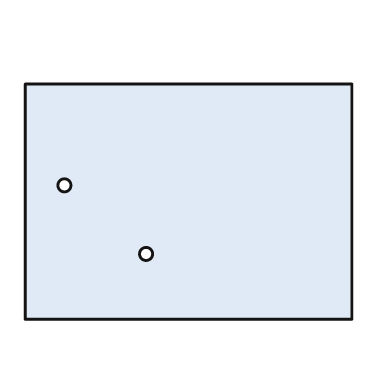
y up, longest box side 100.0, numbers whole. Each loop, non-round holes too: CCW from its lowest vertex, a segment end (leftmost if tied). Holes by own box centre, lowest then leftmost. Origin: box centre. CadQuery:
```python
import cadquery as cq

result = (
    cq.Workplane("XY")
    .moveTo(-50.0, -36.0)
    .lineTo(50.0, -36.0)
    .lineTo(50.0, 36.0)
    .lineTo(-50.0, 36.0)
    .close()
    .moveTo(-13.0, -16.0)
    .circle(2.0)
    .moveTo(-38.0, 5.0)
    .circle(2.0)
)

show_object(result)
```